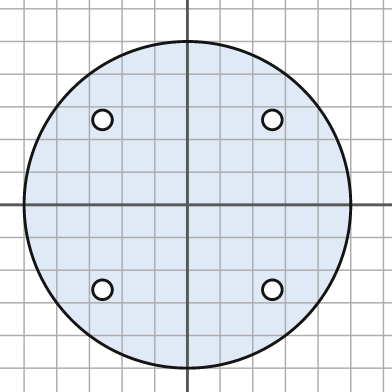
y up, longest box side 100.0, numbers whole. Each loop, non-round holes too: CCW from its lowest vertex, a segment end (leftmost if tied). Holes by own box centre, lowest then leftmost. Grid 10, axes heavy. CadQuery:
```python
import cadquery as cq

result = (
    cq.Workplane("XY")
    .moveTo(0.0, 0.0)
    .circle(50.0)
    .moveTo(-26.0, -26.0)
    .circle(3.0)
    .moveTo(26.0, -26.0)
    .circle(3.0)
    .moveTo(-26.0, 26.0)
    .circle(3.0)
    .moveTo(26.0, 26.0)
    .circle(3.0)
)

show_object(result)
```